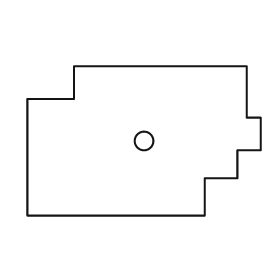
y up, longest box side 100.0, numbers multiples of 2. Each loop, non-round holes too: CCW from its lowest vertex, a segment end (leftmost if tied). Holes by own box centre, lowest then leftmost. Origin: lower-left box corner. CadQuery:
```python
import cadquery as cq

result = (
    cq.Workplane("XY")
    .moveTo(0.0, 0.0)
    .lineTo(76.0, 0.0)
    .lineTo(76.0, 16.0)
    .lineTo(90.0, 16.0)
    .lineTo(90.0, 28.0)
    .lineTo(100.0, 28.0)
    .lineTo(100.0, 42.0)
    .lineTo(94.0, 42.0)
    .lineTo(94.0, 64.0)
    .lineTo(20.0, 64.0)
    .lineTo(20.0, 50.0)
    .lineTo(0.0, 50.0)
    .close()
    .moveTo(50.0, 32.0)
    .circle(4.0)
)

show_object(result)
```